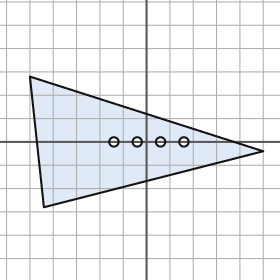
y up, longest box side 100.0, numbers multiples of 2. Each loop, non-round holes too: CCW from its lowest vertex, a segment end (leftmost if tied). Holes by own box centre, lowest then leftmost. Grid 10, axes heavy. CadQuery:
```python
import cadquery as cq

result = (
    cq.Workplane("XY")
    .moveTo(-44.0, -28.0)
    .lineTo(50.0, -4.0)
    .lineTo(-50.0, 28.0)
    .close()
    .moveTo(-14.0, 0.0)
    .circle(2.0)
    .moveTo(-4.0, 0.0)
    .circle(2.0)
    .moveTo(6.0, 0.0)
    .circle(2.0)
    .moveTo(16.0, 0.0)
    .circle(2.0)
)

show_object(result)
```